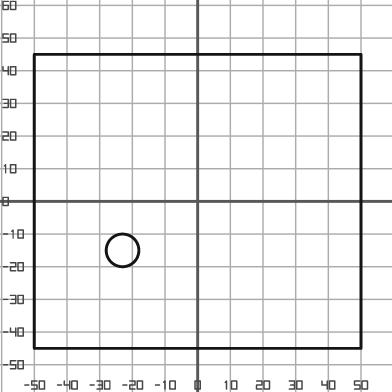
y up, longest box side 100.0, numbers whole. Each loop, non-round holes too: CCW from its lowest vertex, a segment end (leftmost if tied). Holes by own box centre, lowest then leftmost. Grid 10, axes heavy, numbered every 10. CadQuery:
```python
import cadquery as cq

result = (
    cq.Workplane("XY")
    .moveTo(-50.0, -45.0)
    .lineTo(50.0, -45.0)
    .lineTo(50.0, 45.0)
    .lineTo(-50.0, 45.0)
    .close()
    .moveTo(-23.0, -15.0)
    .circle(5.0)
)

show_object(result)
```